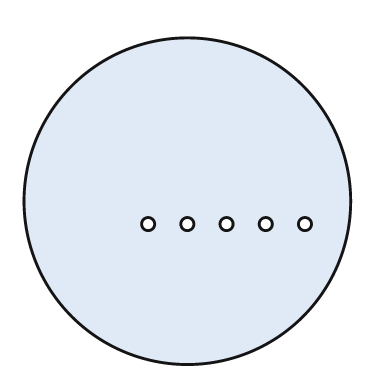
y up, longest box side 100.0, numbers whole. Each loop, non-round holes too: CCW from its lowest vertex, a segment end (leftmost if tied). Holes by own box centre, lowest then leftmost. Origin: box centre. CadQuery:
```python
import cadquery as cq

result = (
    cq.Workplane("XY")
    .moveTo(0.0, 0.0)
    .circle(50.0)
    .moveTo(-12.0, -7.0)
    .circle(2.0)
    .moveTo(0.0, -7.0)
    .circle(2.0)
    .moveTo(12.0, -7.0)
    .circle(2.0)
    .moveTo(24.0, -7.0)
    .circle(2.0)
    .moveTo(36.0, -7.0)
    .circle(2.0)
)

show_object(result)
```